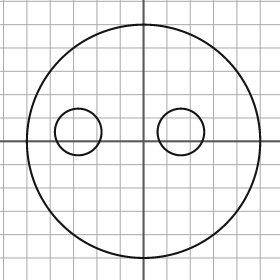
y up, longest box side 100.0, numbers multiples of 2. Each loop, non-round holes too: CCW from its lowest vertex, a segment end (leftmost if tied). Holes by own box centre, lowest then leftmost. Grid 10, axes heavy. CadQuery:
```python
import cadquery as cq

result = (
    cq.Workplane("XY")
    .moveTo(0.0, 0.0)
    .circle(50.0)
    .moveTo(-28.0, 4.0)
    .circle(10.0)
    .moveTo(16.0, 4.0)
    .circle(10.0)
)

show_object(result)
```